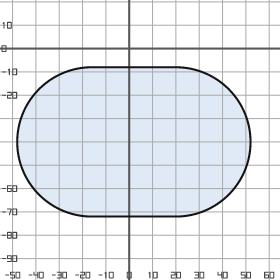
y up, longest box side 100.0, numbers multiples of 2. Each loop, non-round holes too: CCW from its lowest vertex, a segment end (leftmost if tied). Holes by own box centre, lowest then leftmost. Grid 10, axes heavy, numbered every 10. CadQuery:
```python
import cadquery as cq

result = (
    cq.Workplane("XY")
    .moveTo(-16.0, -72.0)
    .lineTo(20.0, -72.0)
    .threePointArc((52.0, -40.0), (20.0, -8.0))
    .lineTo(-16.0, -8.0)
    .threePointArc((-48.0, -40.0), (-16.0, -72.0))
    .close()
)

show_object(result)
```